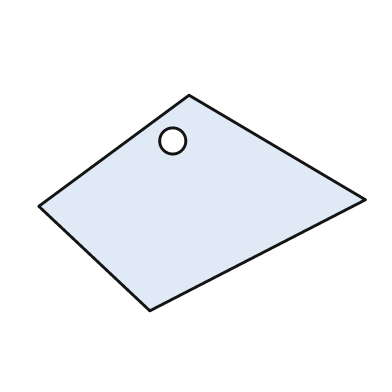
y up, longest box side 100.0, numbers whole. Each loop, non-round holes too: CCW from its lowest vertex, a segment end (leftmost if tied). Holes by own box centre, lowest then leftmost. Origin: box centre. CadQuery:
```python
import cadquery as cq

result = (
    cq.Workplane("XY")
    .moveTo(-16.0, -33.0)
    .lineTo(50.0, 1.0)
    .lineTo(-4.0, 33.0)
    .lineTo(-50.0, -1.0)
    .close()
    .moveTo(-9.0, 19.0)
    .circle(4.0)
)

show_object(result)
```